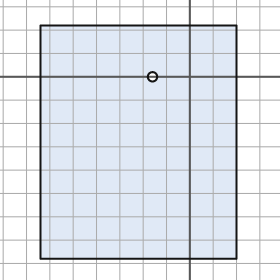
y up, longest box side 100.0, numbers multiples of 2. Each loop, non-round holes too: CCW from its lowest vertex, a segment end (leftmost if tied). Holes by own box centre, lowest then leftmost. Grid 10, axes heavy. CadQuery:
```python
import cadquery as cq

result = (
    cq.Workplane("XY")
    .moveTo(-64.0, -78.0)
    .lineTo(20.0, -78.0)
    .lineTo(20.0, 22.0)
    .lineTo(-64.0, 22.0)
    .close()
    .moveTo(-16.0, 0.0)
    .circle(2.0)
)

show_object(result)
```